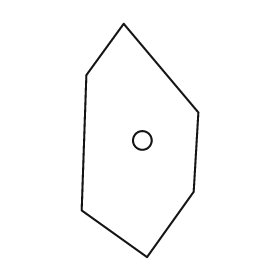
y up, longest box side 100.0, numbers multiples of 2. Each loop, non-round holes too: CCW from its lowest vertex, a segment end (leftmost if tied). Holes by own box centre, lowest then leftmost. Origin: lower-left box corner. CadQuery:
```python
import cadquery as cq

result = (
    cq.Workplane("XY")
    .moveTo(28.0, 0.0)
    .lineTo(48.0, 28.0)
    .lineTo(50.0, 62.0)
    .lineTo(18.0, 100.0)
    .lineTo(2.0, 78.0)
    .lineTo(0.0, 20.0)
    .close()
    .moveTo(26.0, 50.0)
    .circle(4.0)
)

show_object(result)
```